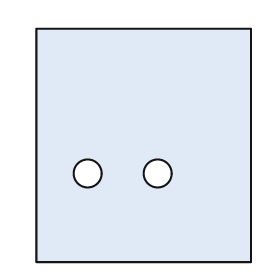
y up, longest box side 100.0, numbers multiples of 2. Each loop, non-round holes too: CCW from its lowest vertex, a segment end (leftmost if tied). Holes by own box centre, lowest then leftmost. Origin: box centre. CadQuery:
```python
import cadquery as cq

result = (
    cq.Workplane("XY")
    .moveTo(-46.0, -50.0)
    .lineTo(46.0, -50.0)
    .lineTo(46.0, 50.0)
    .lineTo(-46.0, 50.0)
    .close()
    .moveTo(-24.0, -12.0)
    .circle(6.0)
    .moveTo(6.0, -12.0)
    .circle(6.0)
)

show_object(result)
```